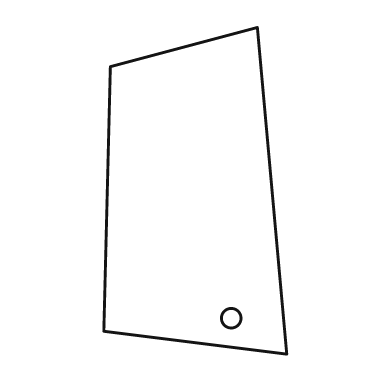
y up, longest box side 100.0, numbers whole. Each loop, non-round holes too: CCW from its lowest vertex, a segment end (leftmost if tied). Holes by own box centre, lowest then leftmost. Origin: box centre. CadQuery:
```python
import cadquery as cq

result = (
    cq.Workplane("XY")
    .moveTo(28.0, -50.0)
    .lineTo(19.0, 50.0)
    .lineTo(-26.0, 38.0)
    .lineTo(-28.0, -43.0)
    .close()
    .moveTo(11.0, -39.0)
    .circle(3.0)
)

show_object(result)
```